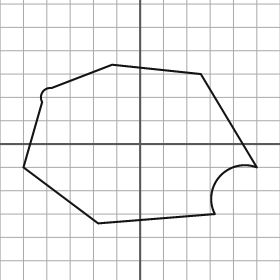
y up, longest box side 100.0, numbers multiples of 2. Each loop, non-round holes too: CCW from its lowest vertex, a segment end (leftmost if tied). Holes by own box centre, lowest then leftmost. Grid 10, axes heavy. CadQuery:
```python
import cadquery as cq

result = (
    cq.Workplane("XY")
    .moveTo(-18.0, -34.0)
    .lineTo(32.0, -30.0)
    .threePointArc((34.0, -14.0), (50.0, -10.0))
    .lineTo(26.0, 30.0)
    .lineTo(-12.0, 34.0)
    .lineTo(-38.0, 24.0)
    .threePointArc((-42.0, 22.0), (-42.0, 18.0))
    .lineTo(-50.0, -10.0)
    .close()
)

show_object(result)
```